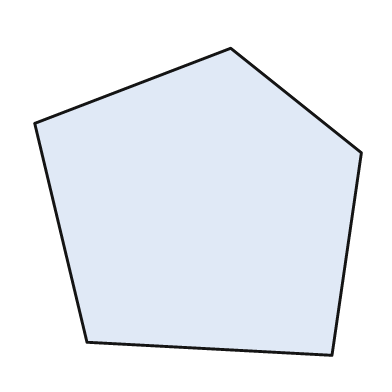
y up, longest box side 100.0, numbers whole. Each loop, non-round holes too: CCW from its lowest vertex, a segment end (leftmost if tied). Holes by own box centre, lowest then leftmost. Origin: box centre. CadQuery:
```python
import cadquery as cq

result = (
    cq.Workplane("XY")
    .moveTo(41.0, -47.0)
    .lineTo(50.0, 15.0)
    .lineTo(10.0, 47.0)
    .lineTo(-50.0, 24.0)
    .lineTo(-34.0, -43.0)
    .close()
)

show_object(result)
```